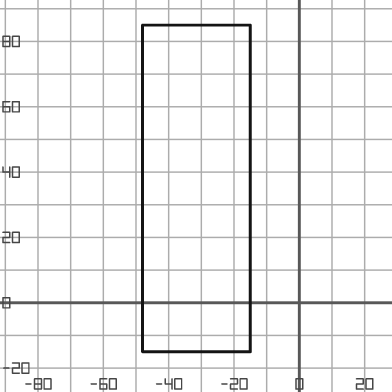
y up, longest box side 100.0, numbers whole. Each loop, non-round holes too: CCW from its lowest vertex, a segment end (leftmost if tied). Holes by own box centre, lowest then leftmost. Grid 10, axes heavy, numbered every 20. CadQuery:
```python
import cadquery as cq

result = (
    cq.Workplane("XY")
    .moveTo(-48.0, -15.0)
    .lineTo(-15.0, -15.0)
    .lineTo(-15.0, 85.0)
    .lineTo(-48.0, 85.0)
    .close()
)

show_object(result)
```